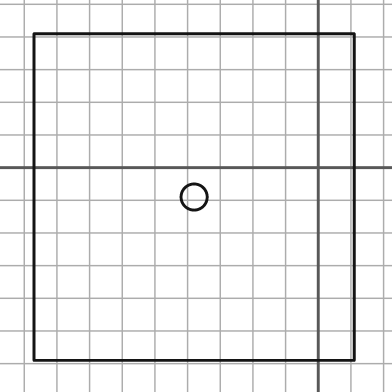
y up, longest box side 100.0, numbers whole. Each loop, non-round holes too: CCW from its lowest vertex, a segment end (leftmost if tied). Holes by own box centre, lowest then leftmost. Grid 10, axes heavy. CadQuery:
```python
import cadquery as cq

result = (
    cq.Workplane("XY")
    .moveTo(-87.0, -59.0)
    .lineTo(11.0, -59.0)
    .lineTo(11.0, 41.0)
    .lineTo(-87.0, 41.0)
    .close()
    .moveTo(-38.0, -9.0)
    .circle(4.0)
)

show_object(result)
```